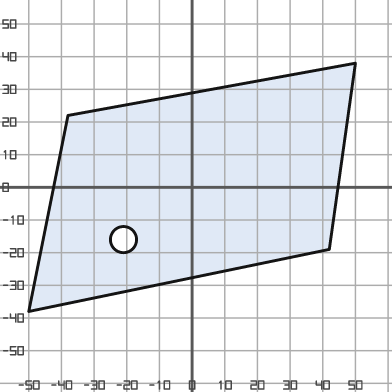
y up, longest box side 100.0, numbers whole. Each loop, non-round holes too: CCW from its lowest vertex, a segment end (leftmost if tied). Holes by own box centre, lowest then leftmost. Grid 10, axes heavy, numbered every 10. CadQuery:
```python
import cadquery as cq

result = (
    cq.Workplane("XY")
    .moveTo(-50.0, -38.0)
    .lineTo(42.0, -19.0)
    .lineTo(50.0, 38.0)
    .lineTo(-38.0, 22.0)
    .close()
    .moveTo(-21.0, -16.0)
    .circle(4.0)
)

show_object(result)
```